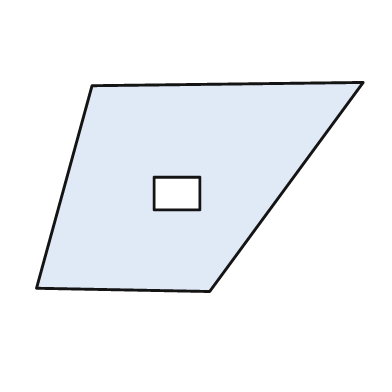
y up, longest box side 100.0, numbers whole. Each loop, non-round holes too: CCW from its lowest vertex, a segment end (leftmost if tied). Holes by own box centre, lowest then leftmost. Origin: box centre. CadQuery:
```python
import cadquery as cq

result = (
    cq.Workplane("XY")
    .moveTo(3.0, -32.0)
    .lineTo(50.0, 32.0)
    .lineTo(-33.0, 31.0)
    .lineTo(-50.0, -31.0)
    .close()
    .moveTo(-14.0, -7.0)
    .lineTo(0.0, -7.0)
    .lineTo(0.0, 3.0)
    .lineTo(-14.0, 3.0)
    .close()
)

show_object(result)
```